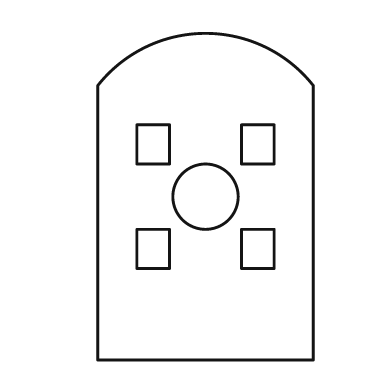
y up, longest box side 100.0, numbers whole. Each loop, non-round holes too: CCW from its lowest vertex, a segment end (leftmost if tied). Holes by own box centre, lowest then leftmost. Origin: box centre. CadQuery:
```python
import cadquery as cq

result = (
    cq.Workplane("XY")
    .moveTo(-33.0, -50.0)
    .lineTo(33.0, -50.0)
    .lineTo(33.0, 34.0)
    .threePointArc((0.0, 50.0), (-33.0, 34.0))
    .close()
    .moveTo(-21.0, -22.0)
    .lineTo(-11.0, -22.0)
    .lineTo(-11.0, -10.0)
    .lineTo(-21.0, -10.0)
    .close()
    .moveTo(11.0, -22.0)
    .lineTo(21.0, -22.0)
    .lineTo(21.0, -10.0)
    .lineTo(11.0, -10.0)
    .close()
    .moveTo(0.0, 0.0)
    .circle(10.0)
    .moveTo(-21.0, 10.0)
    .lineTo(-11.0, 10.0)
    .lineTo(-11.0, 22.0)
    .lineTo(-21.0, 22.0)
    .close()
    .moveTo(11.0, 10.0)
    .lineTo(21.0, 10.0)
    .lineTo(21.0, 22.0)
    .lineTo(11.0, 22.0)
    .close()
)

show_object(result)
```